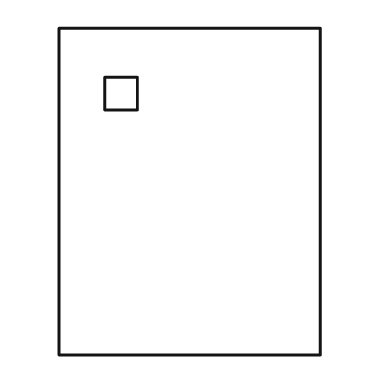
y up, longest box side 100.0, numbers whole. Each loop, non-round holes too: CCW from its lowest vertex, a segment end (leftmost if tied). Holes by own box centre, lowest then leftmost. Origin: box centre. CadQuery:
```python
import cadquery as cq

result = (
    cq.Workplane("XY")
    .moveTo(-40.0, -50.0)
    .lineTo(40.0, -50.0)
    .lineTo(40.0, 50.0)
    .lineTo(-40.0, 50.0)
    .close()
    .moveTo(-26.0, 25.0)
    .lineTo(-16.0, 25.0)
    .lineTo(-16.0, 35.0)
    .lineTo(-26.0, 35.0)
    .close()
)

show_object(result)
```